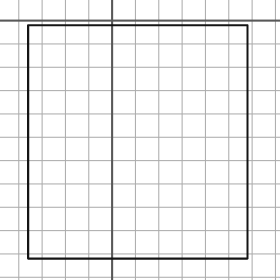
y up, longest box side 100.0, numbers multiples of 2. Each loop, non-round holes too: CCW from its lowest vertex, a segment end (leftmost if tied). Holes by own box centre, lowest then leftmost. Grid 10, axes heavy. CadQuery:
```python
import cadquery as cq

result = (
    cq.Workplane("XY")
    .moveTo(-36.0, -102.0)
    .lineTo(58.0, -102.0)
    .lineTo(58.0, -2.0)
    .lineTo(-36.0, -2.0)
    .close()
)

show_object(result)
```